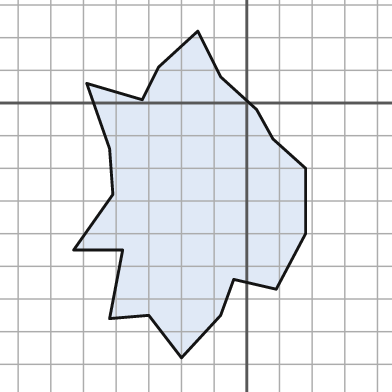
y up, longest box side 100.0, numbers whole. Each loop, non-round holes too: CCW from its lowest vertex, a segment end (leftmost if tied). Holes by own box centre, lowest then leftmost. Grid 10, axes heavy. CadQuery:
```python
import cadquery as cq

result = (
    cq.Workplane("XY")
    .moveTo(-20.0, -78.0)
    .lineTo(-8.0, -65.0)
    .lineTo(-4.0, -54.0)
    .lineTo(9.0, -57.0)
    .lineTo(18.0, -40.0)
    .lineTo(18.0, -20.0)
    .lineTo(8.0, -11.0)
    .lineTo(3.0, -2.0)
    .lineTo(-8.0, 8.0)
    .lineTo(-15.0, 22.0)
    .lineTo(-27.0, 11.0)
    .lineTo(-32.0, 1.0)
    .lineTo(-49.0, 6.0)
    .lineTo(-42.0, -14.0)
    .lineTo(-41.0, -28.0)
    .lineTo(-53.0, -45.0)
    .lineTo(-38.0, -45.0)
    .lineTo(-42.0, -66.0)
    .lineTo(-30.0, -65.0)
    .close()
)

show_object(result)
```